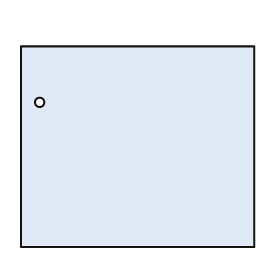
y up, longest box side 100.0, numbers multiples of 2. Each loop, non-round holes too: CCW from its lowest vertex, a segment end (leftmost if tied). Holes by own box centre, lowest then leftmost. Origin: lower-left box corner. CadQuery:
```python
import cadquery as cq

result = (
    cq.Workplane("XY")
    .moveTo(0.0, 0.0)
    .lineTo(100.0, 0.0)
    .lineTo(100.0, 86.0)
    .lineTo(0.0, 86.0)
    .close()
    .moveTo(8.0, 62.0)
    .circle(2.0)
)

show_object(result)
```